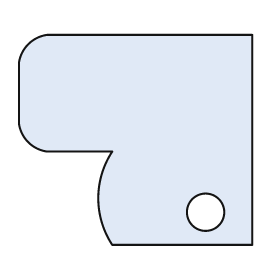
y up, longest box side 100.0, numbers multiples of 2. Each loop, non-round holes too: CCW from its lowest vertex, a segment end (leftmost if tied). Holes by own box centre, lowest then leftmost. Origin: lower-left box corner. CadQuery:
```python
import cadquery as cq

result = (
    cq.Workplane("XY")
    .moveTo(40.0, 0.0)
    .lineTo(100.0, 0.0)
    .lineTo(100.0, 90.0)
    .lineTo(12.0, 90.0)
    .threePointArc((4.0, 86.0), (0.0, 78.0))
    .lineTo(0.0, 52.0)
    .threePointArc((4.0, 44.0), (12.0, 40.0))
    .lineTo(40.0, 40.0)
    .threePointArc((34.0, 20.0), (40.0, 0.0))
    .close()
    .moveTo(80.0, 14.0)
    .circle(8.0)
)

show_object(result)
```